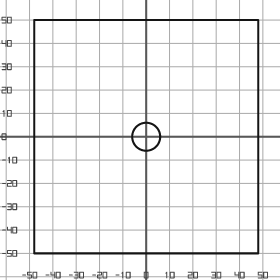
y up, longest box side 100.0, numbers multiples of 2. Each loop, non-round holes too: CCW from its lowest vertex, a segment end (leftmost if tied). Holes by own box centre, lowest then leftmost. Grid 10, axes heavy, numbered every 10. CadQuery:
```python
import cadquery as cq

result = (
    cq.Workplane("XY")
    .moveTo(-48.0, -50.0)
    .lineTo(48.0, -50.0)
    .lineTo(48.0, 50.0)
    .lineTo(-48.0, 50.0)
    .close()
    .moveTo(0.0, 0.0)
    .circle(6.0)
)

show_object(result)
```